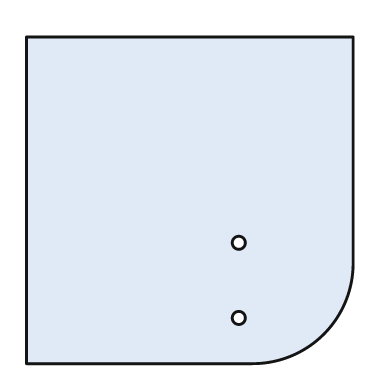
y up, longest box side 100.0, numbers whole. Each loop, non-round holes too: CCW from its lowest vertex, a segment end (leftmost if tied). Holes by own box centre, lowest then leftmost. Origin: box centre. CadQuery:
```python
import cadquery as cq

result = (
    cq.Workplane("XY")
    .moveTo(-50.0, -50.0)
    .lineTo(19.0, -50.0)
    .threePointArc((41.0, -41.0), (50.0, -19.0))
    .lineTo(50.0, 50.0)
    .lineTo(-50.0, 50.0)
    .close()
    .moveTo(15.0, -36.0)
    .circle(2.0)
    .moveTo(15.0, -13.0)
    .circle(2.0)
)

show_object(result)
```